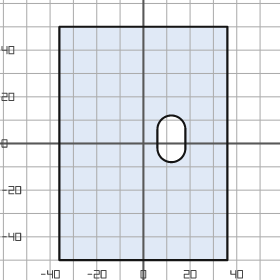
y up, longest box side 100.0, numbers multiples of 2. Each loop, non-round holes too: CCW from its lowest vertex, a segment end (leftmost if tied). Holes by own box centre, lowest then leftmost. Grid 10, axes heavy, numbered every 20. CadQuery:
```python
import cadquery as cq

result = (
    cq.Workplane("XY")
    .moveTo(-36.0, -50.0)
    .lineTo(36.0, -50.0)
    .lineTo(36.0, 50.0)
    .lineTo(-36.0, 50.0)
    .close()
    .moveTo(6.0, -2.0)
    .threePointArc((12.0, -8.0), (18.0, -2.0))
    .lineTo(18.0, 6.0)
    .threePointArc((12.0, 12.0), (6.0, 6.0))
    .close()
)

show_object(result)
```